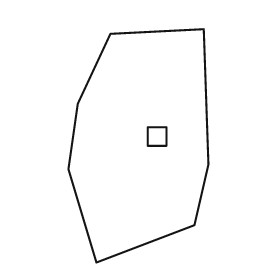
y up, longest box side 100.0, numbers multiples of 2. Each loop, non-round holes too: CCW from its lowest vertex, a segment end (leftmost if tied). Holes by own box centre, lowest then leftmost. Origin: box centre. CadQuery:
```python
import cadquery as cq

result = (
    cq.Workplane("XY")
    .moveTo(-18.0, -50.0)
    .lineTo(24.0, -34.0)
    .lineTo(30.0, -8.0)
    .lineTo(28.0, 50.0)
    .lineTo(-12.0, 48.0)
    .lineTo(-26.0, 18.0)
    .lineTo(-30.0, -10.0)
    .close()
    .moveTo(4.0, 0.0)
    .lineTo(12.0, 0.0)
    .lineTo(12.0, 8.0)
    .lineTo(4.0, 8.0)
    .close()
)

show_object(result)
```